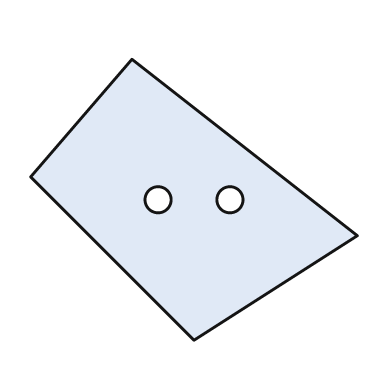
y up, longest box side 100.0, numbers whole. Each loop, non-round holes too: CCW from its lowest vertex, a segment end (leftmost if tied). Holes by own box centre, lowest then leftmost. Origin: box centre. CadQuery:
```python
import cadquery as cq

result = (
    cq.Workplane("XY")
    .moveTo(0.0, -43.0)
    .lineTo(50.0, -11.0)
    .lineTo(-19.0, 43.0)
    .lineTo(-50.0, 7.0)
    .close()
    .moveTo(-11.0, 0.0)
    .circle(4.0)
    .moveTo(11.0, 0.0)
    .circle(4.0)
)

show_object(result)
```